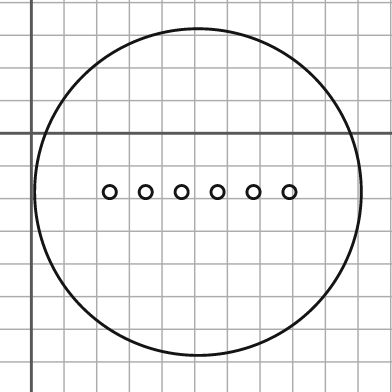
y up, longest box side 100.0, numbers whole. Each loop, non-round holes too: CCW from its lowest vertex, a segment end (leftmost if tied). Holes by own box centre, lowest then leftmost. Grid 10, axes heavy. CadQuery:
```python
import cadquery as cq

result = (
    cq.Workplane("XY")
    .moveTo(51.0, -18.0)
    .circle(50.0)
    .moveTo(24.0, -18.0)
    .circle(2.0)
    .moveTo(35.0, -18.0)
    .circle(2.0)
    .moveTo(46.0, -18.0)
    .circle(2.0)
    .moveTo(57.0, -18.0)
    .circle(2.0)
    .moveTo(68.0, -18.0)
    .circle(2.0)
    .moveTo(79.0, -18.0)
    .circle(2.0)
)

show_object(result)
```